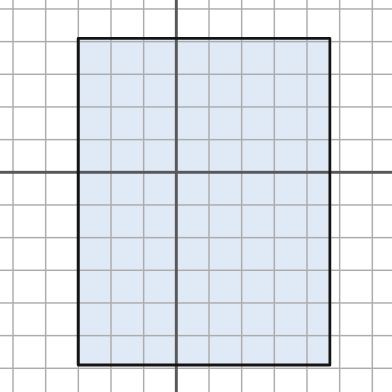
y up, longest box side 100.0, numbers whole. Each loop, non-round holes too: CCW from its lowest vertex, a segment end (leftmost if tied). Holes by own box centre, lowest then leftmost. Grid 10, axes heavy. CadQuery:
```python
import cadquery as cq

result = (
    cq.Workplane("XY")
    .moveTo(-30.0, -59.0)
    .lineTo(47.0, -59.0)
    .lineTo(47.0, 41.0)
    .lineTo(-30.0, 41.0)
    .close()
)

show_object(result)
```